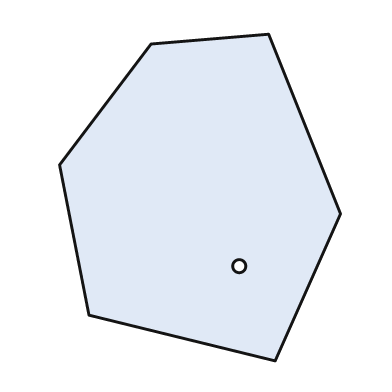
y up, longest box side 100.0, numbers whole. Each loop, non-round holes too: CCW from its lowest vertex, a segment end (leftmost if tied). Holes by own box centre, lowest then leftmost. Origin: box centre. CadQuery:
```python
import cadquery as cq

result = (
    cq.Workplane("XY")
    .moveTo(23.0, -50.0)
    .lineTo(43.0, -5.0)
    .lineTo(21.0, 50.0)
    .lineTo(-15.0, 47.0)
    .lineTo(-43.0, 10.0)
    .lineTo(-34.0, -36.0)
    .close()
    .moveTo(12.0, -21.0)
    .circle(2.0)
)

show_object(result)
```